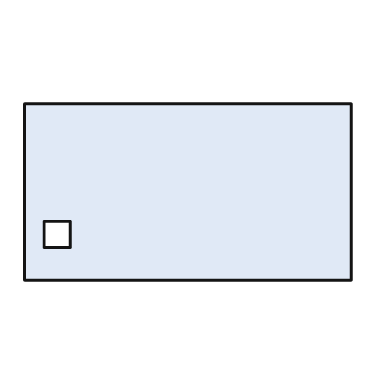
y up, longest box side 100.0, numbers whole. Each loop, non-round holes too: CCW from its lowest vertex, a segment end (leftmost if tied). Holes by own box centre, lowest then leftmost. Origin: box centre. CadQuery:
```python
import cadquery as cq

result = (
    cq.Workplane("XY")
    .moveTo(-50.0, -27.0)
    .lineTo(50.0, -27.0)
    .lineTo(50.0, 27.0)
    .lineTo(-50.0, 27.0)
    .close()
    .moveTo(-44.0, -17.0)
    .lineTo(-36.0, -17.0)
    .lineTo(-36.0, -9.0)
    .lineTo(-44.0, -9.0)
    .close()
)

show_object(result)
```